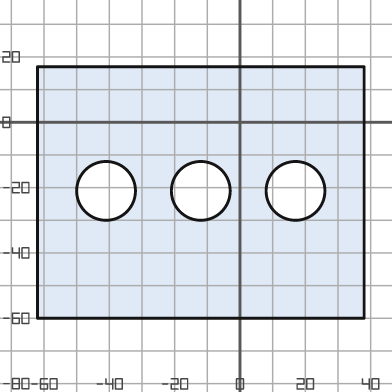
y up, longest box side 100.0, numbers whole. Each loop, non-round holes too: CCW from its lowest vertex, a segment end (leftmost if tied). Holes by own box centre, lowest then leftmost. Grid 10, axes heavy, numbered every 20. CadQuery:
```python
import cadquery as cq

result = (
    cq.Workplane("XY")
    .moveTo(-62.0, -60.0)
    .lineTo(38.0, -60.0)
    .lineTo(38.0, 17.0)
    .lineTo(-62.0, 17.0)
    .close()
    .moveTo(-41.0, -21.0)
    .circle(9.0)
    .moveTo(-12.0, -21.0)
    .circle(9.0)
    .moveTo(17.0, -21.0)
    .circle(9.0)
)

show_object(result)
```